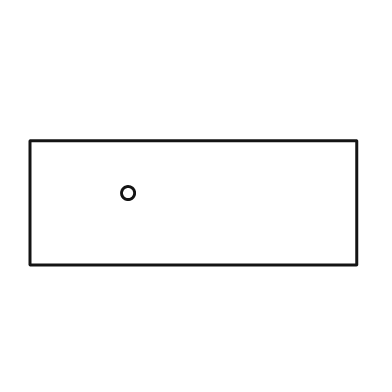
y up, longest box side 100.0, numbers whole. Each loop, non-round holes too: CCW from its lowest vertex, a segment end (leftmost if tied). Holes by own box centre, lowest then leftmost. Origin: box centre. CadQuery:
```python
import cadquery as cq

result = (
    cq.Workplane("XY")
    .moveTo(-50.0, -19.0)
    .lineTo(50.0, -19.0)
    .lineTo(50.0, 19.0)
    .lineTo(-50.0, 19.0)
    .close()
    .moveTo(-20.0, 3.0)
    .circle(2.0)
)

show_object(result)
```